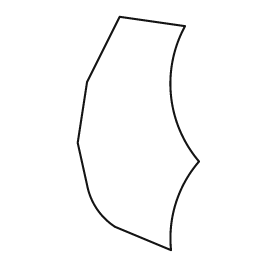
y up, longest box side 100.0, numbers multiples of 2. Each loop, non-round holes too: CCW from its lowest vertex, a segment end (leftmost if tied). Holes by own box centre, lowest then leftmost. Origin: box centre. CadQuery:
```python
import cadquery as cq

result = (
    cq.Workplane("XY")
    .moveTo(14.0, -50.0)
    .threePointArc((16.0, -30.0), (26.0, -12.0))
    .threePointArc((14.0, 16.0), (20.0, 46.0))
    .lineTo(-8.0, 50.0)
    .lineTo(-22.0, 22.0)
    .lineTo(-26.0, -4.0)
    .lineTo(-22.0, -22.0)
    .threePointArc((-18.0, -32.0), (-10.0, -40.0))
    .close()
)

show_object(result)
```